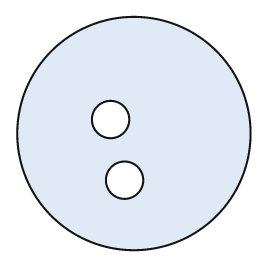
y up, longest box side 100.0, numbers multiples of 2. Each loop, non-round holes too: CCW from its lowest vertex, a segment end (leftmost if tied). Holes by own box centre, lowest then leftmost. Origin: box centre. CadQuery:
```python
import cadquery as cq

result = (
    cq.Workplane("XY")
    .moveTo(0.0, 0.0)
    .circle(50.0)
    .moveTo(-4.0, -20.0)
    .circle(8.0)
    .moveTo(-10.0, 6.0)
    .circle(8.0)
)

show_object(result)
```